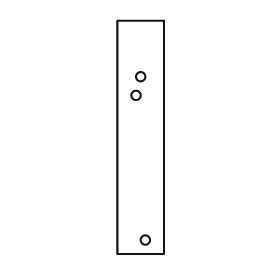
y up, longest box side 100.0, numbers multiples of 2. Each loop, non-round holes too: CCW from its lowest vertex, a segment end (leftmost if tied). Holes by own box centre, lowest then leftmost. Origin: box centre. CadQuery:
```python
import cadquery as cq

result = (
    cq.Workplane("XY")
    .moveTo(-10.0, -50.0)
    .lineTo(10.0, -50.0)
    .lineTo(10.0, 50.0)
    .lineTo(-10.0, 50.0)
    .close()
    .moveTo(2.0, -44.0)
    .circle(2.0)
    .moveTo(-2.0, 18.0)
    .circle(2.0)
    .moveTo(0.0, 26.0)
    .circle(2.0)
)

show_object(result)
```